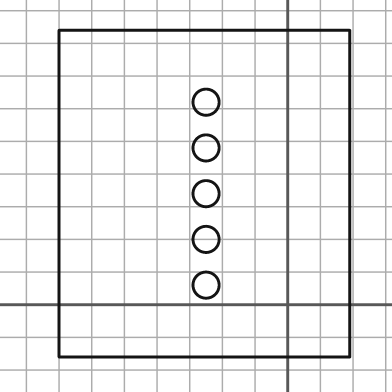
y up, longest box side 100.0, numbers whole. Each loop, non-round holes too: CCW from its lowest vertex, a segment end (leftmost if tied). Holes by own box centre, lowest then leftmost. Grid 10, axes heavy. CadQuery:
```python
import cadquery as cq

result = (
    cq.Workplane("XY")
    .moveTo(-70.0, -16.0)
    .lineTo(19.0, -16.0)
    .lineTo(19.0, 84.0)
    .lineTo(-70.0, 84.0)
    .close()
    .moveTo(-25.0, 6.0)
    .circle(4.0)
    .moveTo(-25.0, 20.0)
    .circle(4.0)
    .moveTo(-25.0, 34.0)
    .circle(4.0)
    .moveTo(-25.0, 48.0)
    .circle(4.0)
    .moveTo(-25.0, 62.0)
    .circle(4.0)
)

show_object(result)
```